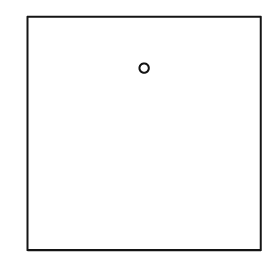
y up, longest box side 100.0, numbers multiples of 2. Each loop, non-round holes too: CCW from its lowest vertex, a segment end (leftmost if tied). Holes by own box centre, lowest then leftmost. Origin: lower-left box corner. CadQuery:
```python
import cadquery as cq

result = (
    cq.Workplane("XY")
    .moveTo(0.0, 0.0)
    .lineTo(100.0, 0.0)
    .lineTo(100.0, 100.0)
    .lineTo(0.0, 100.0)
    .close()
    .moveTo(50.0, 78.0)
    .circle(2.0)
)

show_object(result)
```